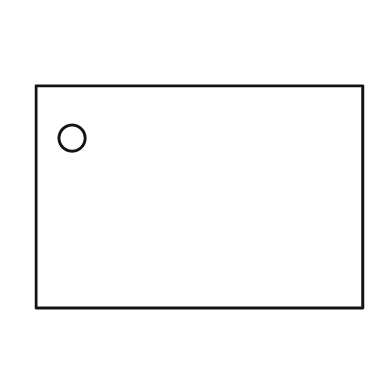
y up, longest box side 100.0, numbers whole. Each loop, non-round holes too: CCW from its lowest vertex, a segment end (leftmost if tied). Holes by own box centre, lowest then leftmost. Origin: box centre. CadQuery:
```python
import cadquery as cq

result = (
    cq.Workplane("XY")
    .moveTo(-50.0, -34.0)
    .lineTo(50.0, -34.0)
    .lineTo(50.0, 34.0)
    .lineTo(-50.0, 34.0)
    .close()
    .moveTo(-39.0, 18.0)
    .circle(4.0)
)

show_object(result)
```